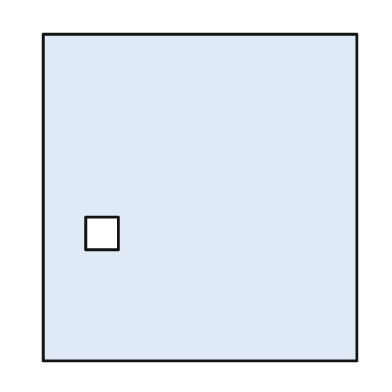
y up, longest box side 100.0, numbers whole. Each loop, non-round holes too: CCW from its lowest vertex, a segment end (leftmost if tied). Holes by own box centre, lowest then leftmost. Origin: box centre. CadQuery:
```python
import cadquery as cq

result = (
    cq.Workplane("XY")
    .moveTo(-48.0, -50.0)
    .lineTo(48.0, -50.0)
    .lineTo(48.0, 50.0)
    .lineTo(-48.0, 50.0)
    .close()
    .moveTo(-35.0, -16.0)
    .lineTo(-25.0, -16.0)
    .lineTo(-25.0, -6.0)
    .lineTo(-35.0, -6.0)
    .close()
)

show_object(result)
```